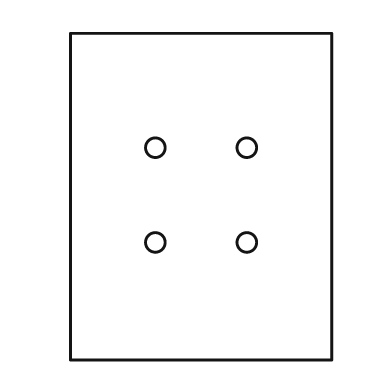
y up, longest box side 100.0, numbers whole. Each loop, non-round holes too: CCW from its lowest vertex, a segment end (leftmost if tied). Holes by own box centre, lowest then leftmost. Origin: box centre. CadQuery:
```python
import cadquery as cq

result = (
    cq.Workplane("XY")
    .moveTo(-40.0, -50.0)
    .lineTo(40.0, -50.0)
    .lineTo(40.0, 50.0)
    .lineTo(-40.0, 50.0)
    .close()
    .moveTo(-14.0, -14.0)
    .circle(3.0)
    .moveTo(14.0, -14.0)
    .circle(3.0)
    .moveTo(-14.0, 15.0)
    .circle(3.0)
    .moveTo(14.0, 15.0)
    .circle(3.0)
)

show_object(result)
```